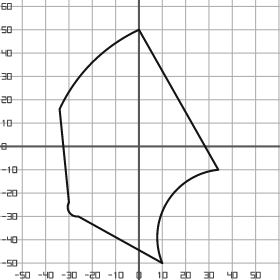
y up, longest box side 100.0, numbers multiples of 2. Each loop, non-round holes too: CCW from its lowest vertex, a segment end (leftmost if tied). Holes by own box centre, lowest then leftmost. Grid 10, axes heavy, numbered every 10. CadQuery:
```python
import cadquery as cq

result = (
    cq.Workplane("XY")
    .moveTo(10.0, -50.0)
    .threePointArc((12.0, -24.0), (34.0, -10.0))
    .lineTo(0.0, 50.0)
    .threePointArc((-20.0, 36.0), (-34.0, 16.0))
    .lineTo(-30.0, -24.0)
    .threePointArc((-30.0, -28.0), (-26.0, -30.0))
    .close()
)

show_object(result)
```